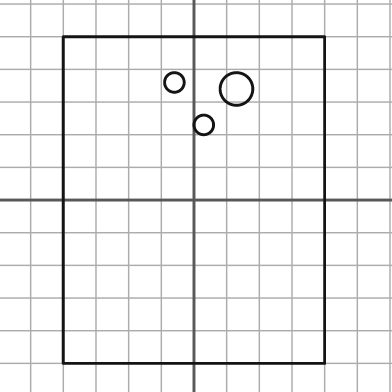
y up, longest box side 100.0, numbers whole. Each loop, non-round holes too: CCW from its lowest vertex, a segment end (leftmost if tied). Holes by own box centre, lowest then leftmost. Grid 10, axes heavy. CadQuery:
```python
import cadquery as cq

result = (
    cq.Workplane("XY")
    .moveTo(-40.0, -50.0)
    .lineTo(40.0, -50.0)
    .lineTo(40.0, 50.0)
    .lineTo(-40.0, 50.0)
    .close()
    .moveTo(3.0, 23.0)
    .circle(3.0)
    .moveTo(13.0, 34.0)
    .circle(5.0)
    .moveTo(-6.0, 36.0)
    .circle(3.0)
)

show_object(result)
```